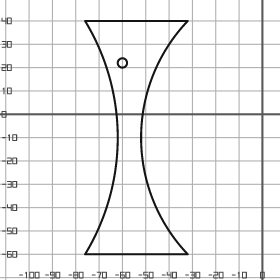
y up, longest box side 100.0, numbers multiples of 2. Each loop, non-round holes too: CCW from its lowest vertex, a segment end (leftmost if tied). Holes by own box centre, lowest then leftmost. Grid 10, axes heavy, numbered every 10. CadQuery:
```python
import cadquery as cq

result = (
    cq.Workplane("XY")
    .moveTo(-76.0, -60.0)
    .lineTo(-32.0, -60.0)
    .threePointArc((-52.0, -10.0), (-32.0, 40.0))
    .lineTo(-76.0, 40.0)
    .threePointArc((-62.0, -10.0), (-76.0, -60.0))
    .close()
    .moveTo(-60.0, 22.0)
    .circle(2.0)
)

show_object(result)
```